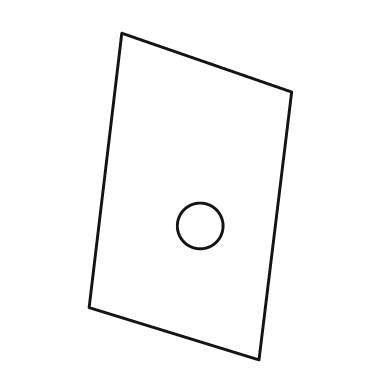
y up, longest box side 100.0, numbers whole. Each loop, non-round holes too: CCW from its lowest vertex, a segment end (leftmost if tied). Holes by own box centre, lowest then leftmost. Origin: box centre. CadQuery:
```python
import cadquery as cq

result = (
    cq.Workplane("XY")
    .moveTo(21.0, -50.0)
    .lineTo(31.0, 32.0)
    .lineTo(-21.0, 50.0)
    .lineTo(-31.0, -34.0)
    .close()
    .moveTo(3.0, -9.0)
    .circle(7.0)
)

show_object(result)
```